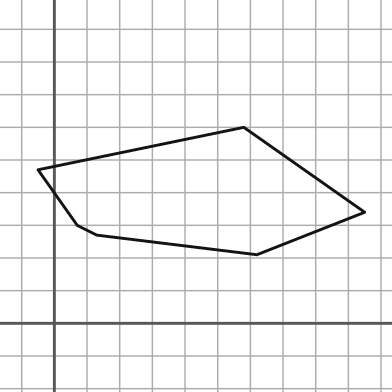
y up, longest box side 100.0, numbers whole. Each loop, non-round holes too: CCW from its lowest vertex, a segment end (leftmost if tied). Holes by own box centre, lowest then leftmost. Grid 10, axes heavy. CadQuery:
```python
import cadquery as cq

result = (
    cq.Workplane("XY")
    .moveTo(62.0, 21.0)
    .lineTo(95.0, 34.0)
    .lineTo(58.0, 60.0)
    .lineTo(-5.0, 47.0)
    .lineTo(7.0, 30.0)
    .lineTo(13.0, 27.0)
    .close()
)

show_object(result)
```